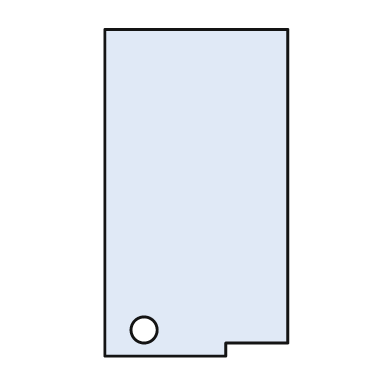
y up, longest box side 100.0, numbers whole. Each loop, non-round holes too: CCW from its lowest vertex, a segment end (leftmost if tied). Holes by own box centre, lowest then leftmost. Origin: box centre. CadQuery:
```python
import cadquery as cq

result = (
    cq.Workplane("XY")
    .moveTo(-28.0, -50.0)
    .lineTo(9.0, -50.0)
    .lineTo(9.0, -46.0)
    .lineTo(28.0, -46.0)
    .lineTo(28.0, 50.0)
    .lineTo(-28.0, 50.0)
    .close()
    .moveTo(-16.0, -42.0)
    .circle(4.0)
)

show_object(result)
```